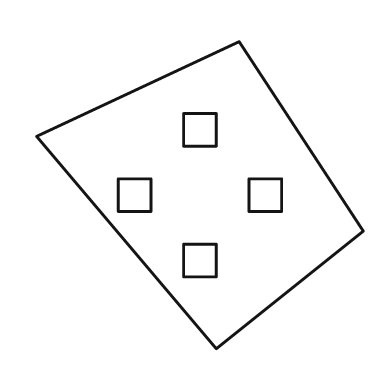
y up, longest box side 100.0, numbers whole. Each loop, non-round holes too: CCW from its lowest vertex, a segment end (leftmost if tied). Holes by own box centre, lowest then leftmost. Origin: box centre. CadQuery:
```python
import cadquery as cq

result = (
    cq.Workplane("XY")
    .moveTo(5.0, -47.0)
    .lineTo(50.0, -11.0)
    .lineTo(12.0, 47.0)
    .lineTo(-50.0, 18.0)
    .close()
    .moveTo(-5.0, -25.0)
    .lineTo(5.0, -25.0)
    .lineTo(5.0, -15.0)
    .lineTo(-5.0, -15.0)
    .close()
    .moveTo(-25.0, -5.0)
    .lineTo(-15.0, -5.0)
    .lineTo(-15.0, 5.0)
    .lineTo(-25.0, 5.0)
    .close()
    .moveTo(15.0, -5.0)
    .lineTo(25.0, -5.0)
    .lineTo(25.0, 5.0)
    .lineTo(15.0, 5.0)
    .close()
    .moveTo(-5.0, 15.0)
    .lineTo(5.0, 15.0)
    .lineTo(5.0, 25.0)
    .lineTo(-5.0, 25.0)
    .close()
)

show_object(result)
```